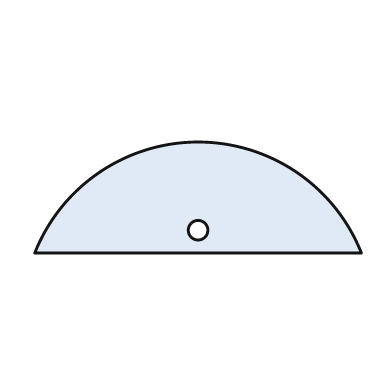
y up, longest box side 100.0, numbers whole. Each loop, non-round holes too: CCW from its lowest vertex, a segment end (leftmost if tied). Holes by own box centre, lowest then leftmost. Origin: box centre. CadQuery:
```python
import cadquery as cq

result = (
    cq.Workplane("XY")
    .moveTo(-50.0, -17.0)
    .lineTo(50.0, -17.0)
    .threePointArc((0.0, 17.0), (-50.0, -17.0))
    .close()
    .moveTo(0.0, -10.0)
    .circle(3.0)
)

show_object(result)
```